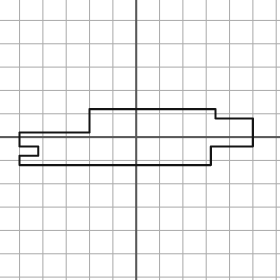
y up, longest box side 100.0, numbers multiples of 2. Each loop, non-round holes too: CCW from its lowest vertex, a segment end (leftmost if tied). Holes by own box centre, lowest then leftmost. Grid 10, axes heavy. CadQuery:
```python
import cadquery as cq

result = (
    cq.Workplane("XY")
    .moveTo(-50.0, -12.0)
    .lineTo(32.0, -12.0)
    .lineTo(32.0, -4.0)
    .lineTo(50.0, -4.0)
    .lineTo(50.0, 8.0)
    .lineTo(34.0, 8.0)
    .lineTo(34.0, 12.0)
    .lineTo(-20.0, 12.0)
    .lineTo(-20.0, 2.0)
    .lineTo(-50.0, 2.0)
    .lineTo(-50.0, -4.0)
    .lineTo(-42.0, -4.0)
    .lineTo(-42.0, -8.0)
    .lineTo(-50.0, -8.0)
    .close()
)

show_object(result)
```